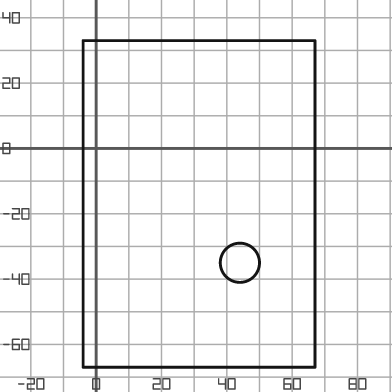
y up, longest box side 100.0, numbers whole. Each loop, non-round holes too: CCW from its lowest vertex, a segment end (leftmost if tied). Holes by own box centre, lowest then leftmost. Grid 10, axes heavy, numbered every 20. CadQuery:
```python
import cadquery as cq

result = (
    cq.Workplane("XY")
    .moveTo(-4.0, -67.0)
    .lineTo(67.0, -67.0)
    .lineTo(67.0, 33.0)
    .lineTo(-4.0, 33.0)
    .close()
    .moveTo(44.0, -35.0)
    .circle(6.0)
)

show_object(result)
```